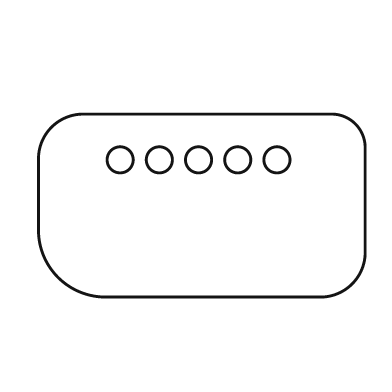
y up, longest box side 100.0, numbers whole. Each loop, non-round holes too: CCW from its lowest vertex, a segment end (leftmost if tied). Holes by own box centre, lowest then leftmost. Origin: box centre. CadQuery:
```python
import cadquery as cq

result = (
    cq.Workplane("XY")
    .moveTo(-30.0, -28.0)
    .lineTo(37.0, -28.0)
    .threePointArc((46.0, -24.0), (50.0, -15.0))
    .lineTo(50.0, 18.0)
    .threePointArc((47.0, 25.0), (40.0, 28.0))
    .lineTo(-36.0, 28.0)
    .threePointArc((-46.0, 24.0), (-50.0, 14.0))
    .lineTo(-50.0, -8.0)
    .threePointArc((-44.0, -22.0), (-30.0, -28.0))
    .close()
    .moveTo(-25.0, 14.0)
    .circle(4.0)
    .moveTo(-13.0, 14.0)
    .circle(4.0)
    .moveTo(-1.0, 14.0)
    .circle(4.0)
    .moveTo(11.0, 14.0)
    .circle(4.0)
    .moveTo(23.0, 14.0)
    .circle(4.0)
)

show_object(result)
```